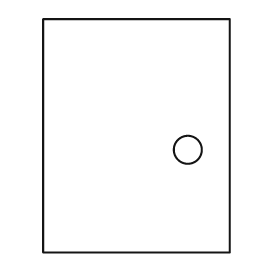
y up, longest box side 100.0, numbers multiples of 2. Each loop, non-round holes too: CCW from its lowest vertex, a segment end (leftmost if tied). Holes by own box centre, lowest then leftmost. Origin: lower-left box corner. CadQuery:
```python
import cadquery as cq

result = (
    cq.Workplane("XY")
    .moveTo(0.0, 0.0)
    .lineTo(80.0, 0.0)
    .lineTo(80.0, 100.0)
    .lineTo(0.0, 100.0)
    .close()
    .moveTo(62.0, 44.0)
    .circle(6.0)
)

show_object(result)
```